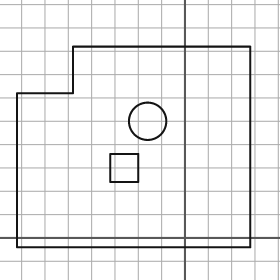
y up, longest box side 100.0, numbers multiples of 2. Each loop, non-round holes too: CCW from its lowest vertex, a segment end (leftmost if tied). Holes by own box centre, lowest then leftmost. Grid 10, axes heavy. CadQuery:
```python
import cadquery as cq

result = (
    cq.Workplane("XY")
    .moveTo(-72.0, -4.0)
    .lineTo(28.0, -4.0)
    .lineTo(28.0, 82.0)
    .lineTo(-48.0, 82.0)
    .lineTo(-48.0, 62.0)
    .lineTo(-72.0, 62.0)
    .close()
    .moveTo(-32.0, 24.0)
    .lineTo(-20.0, 24.0)
    .lineTo(-20.0, 36.0)
    .lineTo(-32.0, 36.0)
    .close()
    .moveTo(-16.0, 50.0)
    .circle(8.0)
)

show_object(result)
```